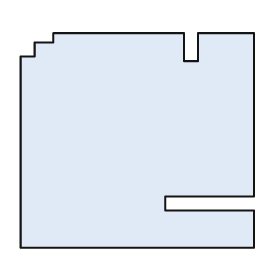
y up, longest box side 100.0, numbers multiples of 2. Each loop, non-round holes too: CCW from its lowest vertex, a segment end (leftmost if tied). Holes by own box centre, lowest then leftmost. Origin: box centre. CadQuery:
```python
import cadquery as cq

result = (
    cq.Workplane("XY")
    .moveTo(-50.0, -46.0)
    .lineTo(50.0, -46.0)
    .lineTo(50.0, -30.0)
    .lineTo(12.0, -30.0)
    .lineTo(12.0, -24.0)
    .lineTo(50.0, -24.0)
    .lineTo(50.0, 46.0)
    .lineTo(26.0, 46.0)
    .lineTo(26.0, 34.0)
    .lineTo(20.0, 34.0)
    .lineTo(20.0, 46.0)
    .lineTo(-36.0, 46.0)
    .lineTo(-36.0, 42.0)
    .lineTo(-44.0, 42.0)
    .lineTo(-44.0, 36.0)
    .lineTo(-50.0, 36.0)
    .close()
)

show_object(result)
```